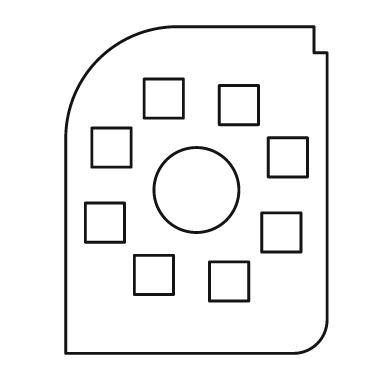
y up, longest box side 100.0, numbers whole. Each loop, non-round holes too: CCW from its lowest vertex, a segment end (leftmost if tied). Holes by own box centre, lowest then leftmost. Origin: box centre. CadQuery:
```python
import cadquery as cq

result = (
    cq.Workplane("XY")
    .moveTo(-40.0, -50.0)
    .lineTo(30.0, -50.0)
    .threePointArc((37.0, -47.0), (40.0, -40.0))
    .lineTo(40.0, 42.0)
    .lineTo(36.0, 42.0)
    .lineTo(36.0, 50.0)
    .lineTo(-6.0, 50.0)
    .threePointArc((-30.0, 40.0), (-40.0, 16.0))
    .close()
    .moveTo(4.0, -34.0)
    .lineTo(16.0, -34.0)
    .lineTo(16.0, -22.0)
    .lineTo(4.0, -22.0)
    .close()
    .moveTo(-19.0, -32.0)
    .lineTo(-7.0, -32.0)
    .lineTo(-7.0, -20.0)
    .lineTo(-19.0, -20.0)
    .close()
    .moveTo(20.0, -19.0)
    .lineTo(32.0, -19.0)
    .lineTo(32.0, -7.0)
    .lineTo(20.0, -7.0)
    .close()
    .moveTo(-34.0, -16.0)
    .lineTo(-22.0, -16.0)
    .lineTo(-22.0, -4.0)
    .lineTo(-34.0, -4.0)
    .close()
    .moveTo(0.0, 0.0)
    .circle(13.0)
    .moveTo(22.0, 4.0)
    .lineTo(34.0, 4.0)
    .lineTo(34.0, 16.0)
    .lineTo(22.0, 16.0)
    .close()
    .moveTo(-32.0, 7.0)
    .lineTo(-20.0, 7.0)
    .lineTo(-20.0, 19.0)
    .lineTo(-32.0, 19.0)
    .close()
    .moveTo(7.0, 20.0)
    .lineTo(19.0, 20.0)
    .lineTo(19.0, 32.0)
    .lineTo(7.0, 32.0)
    .close()
    .moveTo(-16.0, 22.0)
    .lineTo(-4.0, 22.0)
    .lineTo(-4.0, 34.0)
    .lineTo(-16.0, 34.0)
    .close()
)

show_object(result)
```